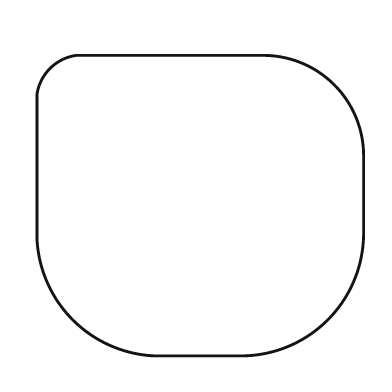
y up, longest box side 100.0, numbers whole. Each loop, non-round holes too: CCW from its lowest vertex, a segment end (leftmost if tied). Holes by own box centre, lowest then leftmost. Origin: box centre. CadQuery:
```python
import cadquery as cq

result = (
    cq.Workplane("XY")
    .moveTo(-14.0, -46.0)
    .lineTo(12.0, -46.0)
    .threePointArc((39.0, -35.0), (50.0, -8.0))
    .lineTo(50.0, 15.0)
    .threePointArc((41.0, 37.0), (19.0, 46.0))
    .lineTo(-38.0, 46.0)
    .threePointArc((-46.0, 42.0), (-50.0, 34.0))
    .lineTo(-50.0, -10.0)
    .threePointArc((-39.0, -35.0), (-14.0, -46.0))
    .close()
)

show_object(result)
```